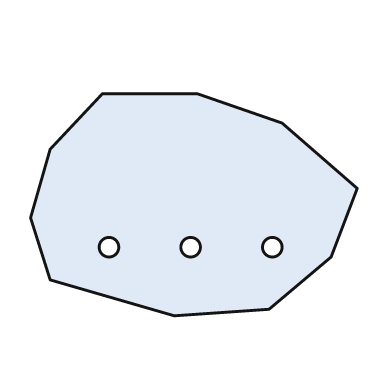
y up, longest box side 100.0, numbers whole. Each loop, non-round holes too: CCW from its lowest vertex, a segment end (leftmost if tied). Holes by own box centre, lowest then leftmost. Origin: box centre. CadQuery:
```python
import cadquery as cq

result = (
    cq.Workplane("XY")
    .moveTo(-6.0, -34.0)
    .lineTo(23.0, -32.0)
    .lineTo(42.0, -16.0)
    .lineTo(50.0, 5.0)
    .lineTo(27.0, 25.0)
    .lineTo(1.0, 34.0)
    .lineTo(-28.0, 34.0)
    .lineTo(-44.0, 17.0)
    .lineTo(-50.0, -4.0)
    .lineTo(-44.0, -23.0)
    .close()
    .moveTo(-26.0, -13.0)
    .circle(3.0)
    .moveTo(-1.0, -13.0)
    .circle(3.0)
    .moveTo(24.0, -13.0)
    .circle(3.0)
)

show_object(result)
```